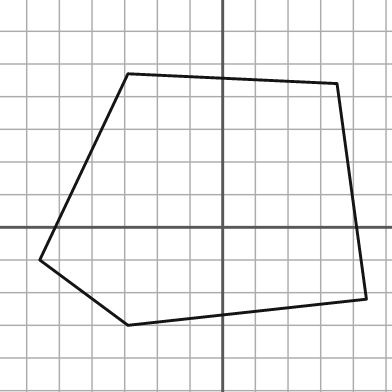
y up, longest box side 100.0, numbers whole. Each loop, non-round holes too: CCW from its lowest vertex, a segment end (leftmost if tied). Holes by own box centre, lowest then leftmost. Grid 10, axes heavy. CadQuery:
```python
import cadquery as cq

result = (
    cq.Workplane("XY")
    .moveTo(-29.0, -30.0)
    .lineTo(44.0, -22.0)
    .lineTo(35.0, 44.0)
    .lineTo(-29.0, 47.0)
    .lineTo(-56.0, -10.0)
    .close()
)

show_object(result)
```